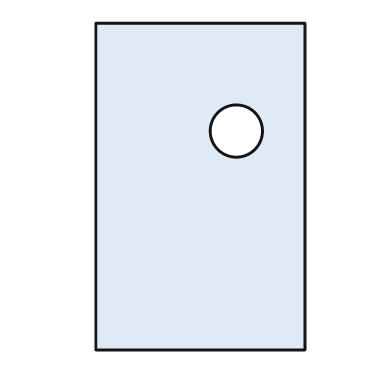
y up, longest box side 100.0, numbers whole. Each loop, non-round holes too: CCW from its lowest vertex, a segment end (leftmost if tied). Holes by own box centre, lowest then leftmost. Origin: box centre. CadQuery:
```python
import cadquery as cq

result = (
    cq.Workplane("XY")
    .moveTo(-32.0, -50.0)
    .lineTo(32.0, -50.0)
    .lineTo(32.0, 50.0)
    .lineTo(-32.0, 50.0)
    .close()
    .moveTo(11.0, 17.0)
    .circle(8.0)
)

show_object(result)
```